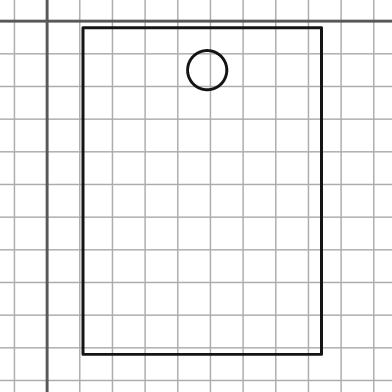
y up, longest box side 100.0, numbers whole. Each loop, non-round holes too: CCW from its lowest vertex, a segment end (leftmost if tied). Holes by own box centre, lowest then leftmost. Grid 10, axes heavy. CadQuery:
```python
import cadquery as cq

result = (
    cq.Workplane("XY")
    .moveTo(11.0, -102.0)
    .lineTo(84.0, -102.0)
    .lineTo(84.0, -2.0)
    .lineTo(11.0, -2.0)
    .close()
    .moveTo(49.0, -15.0)
    .circle(6.0)
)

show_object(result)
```